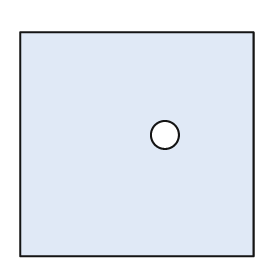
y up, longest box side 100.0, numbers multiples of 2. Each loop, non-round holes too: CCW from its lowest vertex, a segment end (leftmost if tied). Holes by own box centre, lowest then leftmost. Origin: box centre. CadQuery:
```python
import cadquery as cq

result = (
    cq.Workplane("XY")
    .moveTo(-50.0, -48.0)
    .lineTo(50.0, -48.0)
    .lineTo(50.0, 48.0)
    .lineTo(-50.0, 48.0)
    .close()
    .moveTo(12.0, 4.0)
    .circle(6.0)
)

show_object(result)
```